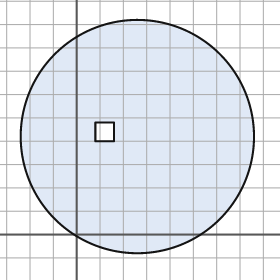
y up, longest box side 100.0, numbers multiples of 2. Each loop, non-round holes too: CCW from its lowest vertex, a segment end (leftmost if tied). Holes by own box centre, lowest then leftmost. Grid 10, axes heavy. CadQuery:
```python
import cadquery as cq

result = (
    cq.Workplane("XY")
    .moveTo(26.0, 42.0)
    .circle(50.0)
    .moveTo(8.0, 40.0)
    .lineTo(16.0, 40.0)
    .lineTo(16.0, 48.0)
    .lineTo(8.0, 48.0)
    .close()
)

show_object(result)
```